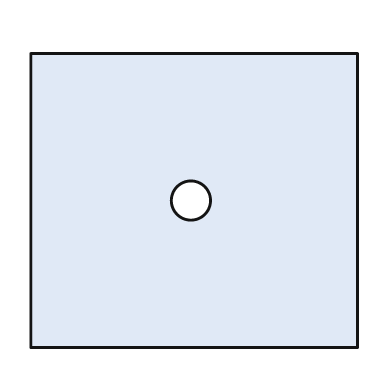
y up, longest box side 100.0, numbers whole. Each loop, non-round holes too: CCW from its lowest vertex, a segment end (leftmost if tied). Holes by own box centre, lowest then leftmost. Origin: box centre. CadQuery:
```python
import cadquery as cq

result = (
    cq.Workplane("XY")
    .moveTo(-50.0, -45.0)
    .lineTo(50.0, -45.0)
    .lineTo(50.0, 45.0)
    .lineTo(-50.0, 45.0)
    .close()
    .moveTo(-1.0, 0.0)
    .circle(6.0)
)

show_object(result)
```